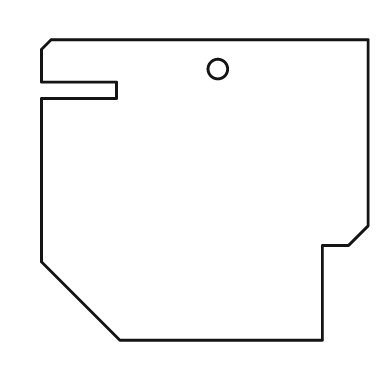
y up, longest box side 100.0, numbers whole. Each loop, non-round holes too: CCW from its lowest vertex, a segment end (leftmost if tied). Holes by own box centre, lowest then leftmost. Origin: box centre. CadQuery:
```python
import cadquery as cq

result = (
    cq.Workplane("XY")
    .moveTo(-26.0, -46.0)
    .lineTo(36.0, -46.0)
    .lineTo(36.0, -17.0)
    .lineTo(44.0, -17.0)
    .lineTo(50.0, -11.0)
    .lineTo(50.0, 46.0)
    .lineTo(-47.0, 46.0)
    .lineTo(-50.0, 43.0)
    .lineTo(-50.0, 33.0)
    .lineTo(-27.0, 33.0)
    .lineTo(-27.0, 28.0)
    .lineTo(-50.0, 28.0)
    .lineTo(-50.0, -22.0)
    .close()
    .moveTo(4.0, 37.0)
    .circle(3.0)
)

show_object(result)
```